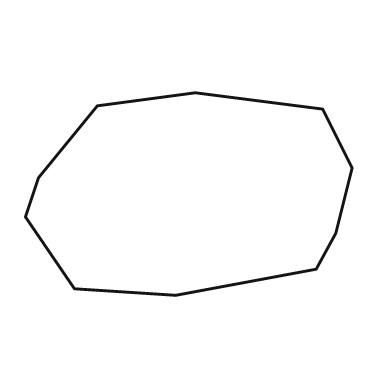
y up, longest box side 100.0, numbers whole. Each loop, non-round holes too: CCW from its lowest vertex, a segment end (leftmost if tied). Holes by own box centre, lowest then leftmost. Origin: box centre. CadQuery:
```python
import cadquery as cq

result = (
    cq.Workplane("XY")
    .moveTo(-4.0, -31.0)
    .lineTo(39.0, -23.0)
    .lineTo(45.0, -12.0)
    .lineTo(50.0, 8.0)
    .lineTo(41.0, 26.0)
    .lineTo(2.0, 31.0)
    .lineTo(-28.0, 27.0)
    .lineTo(-46.0, 5.0)
    .lineTo(-50.0, -7.0)
    .lineTo(-35.0, -29.0)
    .close()
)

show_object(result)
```